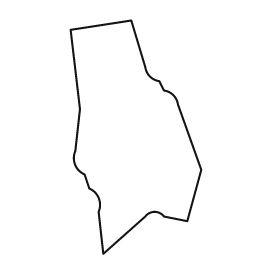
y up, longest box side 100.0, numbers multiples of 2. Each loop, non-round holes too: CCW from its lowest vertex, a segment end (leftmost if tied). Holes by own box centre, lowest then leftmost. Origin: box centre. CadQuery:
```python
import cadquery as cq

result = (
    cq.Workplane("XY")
    .moveTo(-14.0, -50.0)
    .lineTo(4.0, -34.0)
    .threePointArc((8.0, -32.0), (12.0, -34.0))
    .lineTo(22.0, -36.0)
    .lineTo(28.0, -14.0)
    .lineTo(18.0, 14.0)
    .threePointArc((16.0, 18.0), (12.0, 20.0))
    .lineTo(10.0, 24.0)
    .threePointArc((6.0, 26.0), (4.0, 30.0))
    .lineTo(-2.0, 50.0)
    .lineTo(-28.0, 46.0)
    .lineTo(-24.0, 12.0)
    .lineTo(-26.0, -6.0)
    .threePointArc((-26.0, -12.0), (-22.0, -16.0))
    .lineTo(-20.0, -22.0)
    .threePointArc((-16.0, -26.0), (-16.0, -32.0))
    .close()
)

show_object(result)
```